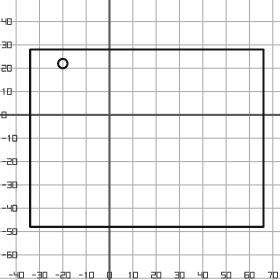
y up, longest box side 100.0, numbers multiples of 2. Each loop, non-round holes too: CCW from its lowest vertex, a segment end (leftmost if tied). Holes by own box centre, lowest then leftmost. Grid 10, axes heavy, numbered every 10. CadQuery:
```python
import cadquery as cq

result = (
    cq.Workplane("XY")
    .moveTo(-34.0, -48.0)
    .lineTo(66.0, -48.0)
    .lineTo(66.0, 28.0)
    .lineTo(-34.0, 28.0)
    .close()
    .moveTo(-20.0, 22.0)
    .circle(2.0)
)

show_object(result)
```